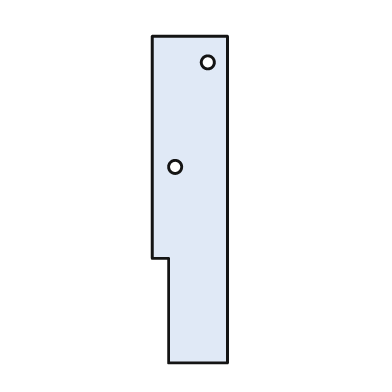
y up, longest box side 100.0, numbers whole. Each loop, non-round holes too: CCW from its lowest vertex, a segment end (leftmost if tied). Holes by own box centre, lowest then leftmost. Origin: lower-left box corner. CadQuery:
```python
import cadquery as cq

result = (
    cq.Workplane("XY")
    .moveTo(5.0, 0.0)
    .lineTo(23.0, 0.0)
    .lineTo(23.0, 100.0)
    .lineTo(0.0, 100.0)
    .lineTo(0.0, 32.0)
    .lineTo(5.0, 32.0)
    .close()
    .moveTo(7.0, 60.0)
    .circle(2.0)
    .moveTo(17.0, 92.0)
    .circle(2.0)
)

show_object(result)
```